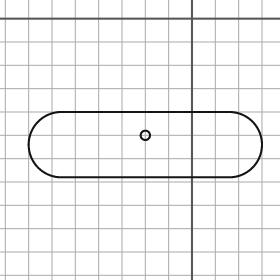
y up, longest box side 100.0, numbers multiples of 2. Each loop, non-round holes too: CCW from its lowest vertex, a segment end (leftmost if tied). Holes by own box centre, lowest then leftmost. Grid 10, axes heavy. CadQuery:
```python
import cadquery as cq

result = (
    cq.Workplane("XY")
    .moveTo(-56.0, -68.0)
    .lineTo(16.0, -68.0)
    .threePointArc((30.0, -54.0), (16.0, -40.0))
    .lineTo(-56.0, -40.0)
    .threePointArc((-70.0, -54.0), (-56.0, -68.0))
    .close()
    .moveTo(-20.0, -50.0)
    .circle(2.0)
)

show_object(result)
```